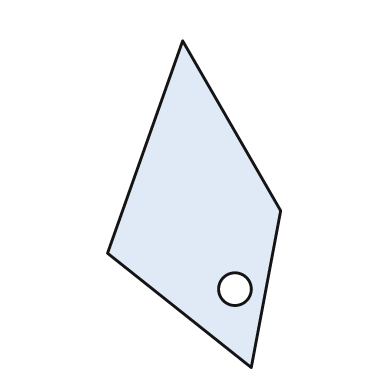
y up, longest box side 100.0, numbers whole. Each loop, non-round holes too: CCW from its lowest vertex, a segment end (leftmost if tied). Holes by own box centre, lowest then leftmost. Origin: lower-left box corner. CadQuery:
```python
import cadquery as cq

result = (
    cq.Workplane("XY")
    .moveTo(44.0, 0.0)
    .lineTo(53.0, 48.0)
    .lineTo(23.0, 100.0)
    .lineTo(0.0, 35.0)
    .close()
    .moveTo(39.0, 24.0)
    .circle(5.0)
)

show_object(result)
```